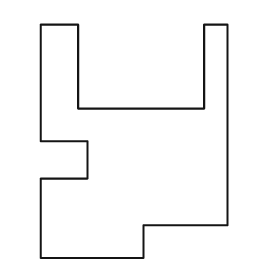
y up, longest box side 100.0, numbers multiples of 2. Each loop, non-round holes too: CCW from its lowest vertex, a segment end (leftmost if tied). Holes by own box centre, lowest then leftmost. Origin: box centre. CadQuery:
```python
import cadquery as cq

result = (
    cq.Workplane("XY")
    .moveTo(-40.0, -50.0)
    .lineTo(4.0, -50.0)
    .lineTo(4.0, -36.0)
    .lineTo(40.0, -36.0)
    .lineTo(40.0, 50.0)
    .lineTo(30.0, 50.0)
    .lineTo(30.0, 14.0)
    .lineTo(-24.0, 14.0)
    .lineTo(-24.0, 50.0)
    .lineTo(-40.0, 50.0)
    .lineTo(-40.0, 0.0)
    .lineTo(-20.0, 0.0)
    .lineTo(-20.0, -16.0)
    .lineTo(-40.0, -16.0)
    .close()
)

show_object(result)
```